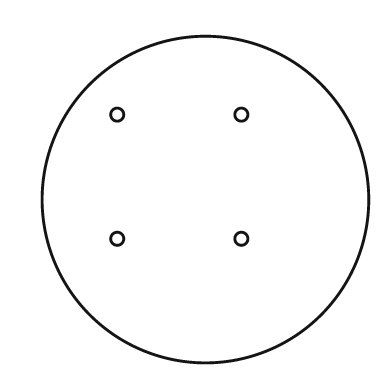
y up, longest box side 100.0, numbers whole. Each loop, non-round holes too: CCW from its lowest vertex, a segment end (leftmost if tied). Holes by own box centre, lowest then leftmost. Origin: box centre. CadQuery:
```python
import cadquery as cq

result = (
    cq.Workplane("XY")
    .moveTo(0.0, 0.0)
    .circle(50.0)
    .moveTo(-27.0, -12.0)
    .circle(2.0)
    .moveTo(11.0, -12.0)
    .circle(2.0)
    .moveTo(-27.0, 26.0)
    .circle(2.0)
    .moveTo(11.0, 26.0)
    .circle(2.0)
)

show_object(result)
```